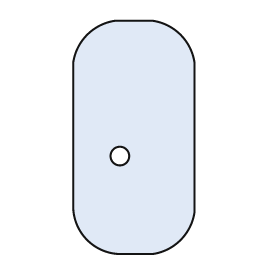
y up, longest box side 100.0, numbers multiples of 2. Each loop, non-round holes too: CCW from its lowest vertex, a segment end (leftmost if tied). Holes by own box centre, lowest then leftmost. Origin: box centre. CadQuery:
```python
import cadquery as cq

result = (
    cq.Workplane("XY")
    .moveTo(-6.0, -50.0)
    .lineTo(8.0, -50.0)
    .threePointArc((20.0, -44.0), (26.0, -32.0))
    .lineTo(26.0, 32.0)
    .threePointArc((20.0, 44.0), (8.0, 50.0))
    .lineTo(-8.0, 50.0)
    .threePointArc((-20.0, 44.0), (-26.0, 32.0))
    .lineTo(-26.0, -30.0)
    .threePointArc((-20.0, -44.0), (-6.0, -50.0))
    .close()
    .moveTo(-6.0, -8.0)
    .circle(4.0)
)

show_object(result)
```